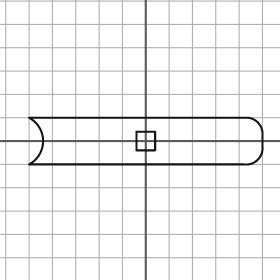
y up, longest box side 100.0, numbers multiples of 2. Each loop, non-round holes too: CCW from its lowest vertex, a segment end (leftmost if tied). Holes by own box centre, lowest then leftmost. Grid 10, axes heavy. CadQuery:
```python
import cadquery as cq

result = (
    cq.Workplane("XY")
    .moveTo(-50.0, -10.0)
    .lineTo(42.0, -10.0)
    .threePointArc((48.0, -8.0), (50.0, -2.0))
    .lineTo(50.0, 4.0)
    .threePointArc((48.0, 8.0), (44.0, 10.0))
    .lineTo(-50.0, 10.0)
    .threePointArc((-44.0, 0.0), (-50.0, -10.0))
    .close()
    .moveTo(-4.0, -4.0)
    .lineTo(4.0, -4.0)
    .lineTo(4.0, 4.0)
    .lineTo(-4.0, 4.0)
    .close()
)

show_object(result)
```